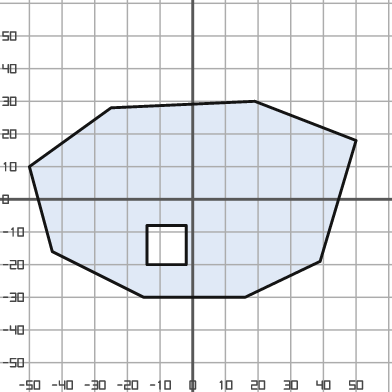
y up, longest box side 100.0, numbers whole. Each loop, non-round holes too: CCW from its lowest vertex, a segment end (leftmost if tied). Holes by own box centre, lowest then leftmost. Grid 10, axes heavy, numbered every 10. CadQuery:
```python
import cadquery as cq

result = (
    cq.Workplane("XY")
    .moveTo(-15.0, -30.0)
    .lineTo(16.0, -30.0)
    .lineTo(39.0, -19.0)
    .lineTo(50.0, 18.0)
    .lineTo(19.0, 30.0)
    .lineTo(-25.0, 28.0)
    .lineTo(-50.0, 10.0)
    .lineTo(-43.0, -16.0)
    .close()
    .moveTo(-14.0, -20.0)
    .lineTo(-2.0, -20.0)
    .lineTo(-2.0, -8.0)
    .lineTo(-14.0, -8.0)
    .close()
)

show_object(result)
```